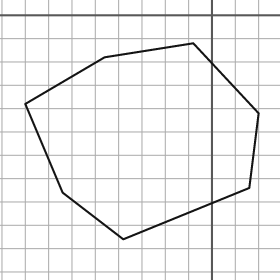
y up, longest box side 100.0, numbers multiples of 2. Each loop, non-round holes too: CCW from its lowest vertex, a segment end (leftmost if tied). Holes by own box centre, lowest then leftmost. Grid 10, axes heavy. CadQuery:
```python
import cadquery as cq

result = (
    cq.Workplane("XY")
    .moveTo(-38.0, -96.0)
    .lineTo(16.0, -74.0)
    .lineTo(20.0, -42.0)
    .lineTo(-8.0, -12.0)
    .lineTo(-46.0, -18.0)
    .lineTo(-80.0, -38.0)
    .lineTo(-64.0, -76.0)
    .close()
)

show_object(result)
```